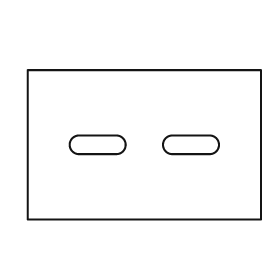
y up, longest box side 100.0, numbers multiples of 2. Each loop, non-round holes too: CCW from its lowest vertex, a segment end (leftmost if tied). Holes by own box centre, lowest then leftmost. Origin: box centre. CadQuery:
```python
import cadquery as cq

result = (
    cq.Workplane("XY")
    .moveTo(-50.0, -32.0)
    .lineTo(50.0, -32.0)
    .lineTo(50.0, 32.0)
    .lineTo(-50.0, 32.0)
    .close()
    .moveTo(-28.0, -4.0)
    .lineTo(-12.0, -4.0)
    .threePointArc((-8.0, 0.0), (-12.0, 4.0))
    .lineTo(-28.0, 4.0)
    .threePointArc((-32.0, 0.0), (-28.0, -4.0))
    .close()
    .moveTo(12.0, -4.0)
    .lineTo(28.0, -4.0)
    .threePointArc((32.0, 0.0), (28.0, 4.0))
    .lineTo(12.0, 4.0)
    .threePointArc((8.0, 0.0), (12.0, -4.0))
    .close()
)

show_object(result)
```